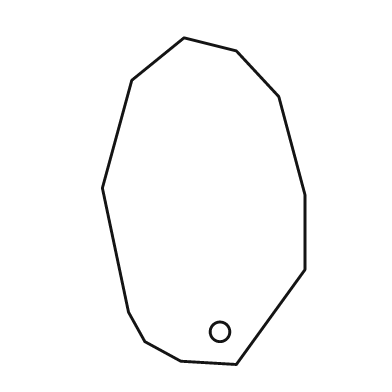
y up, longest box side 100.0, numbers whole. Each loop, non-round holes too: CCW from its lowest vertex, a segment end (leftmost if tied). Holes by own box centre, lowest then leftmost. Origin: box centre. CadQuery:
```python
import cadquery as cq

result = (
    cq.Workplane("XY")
    .moveTo(10.0, -50.0)
    .lineTo(31.0, -21.0)
    .lineTo(31.0, 2.0)
    .lineTo(23.0, 32.0)
    .lineTo(10.0, 46.0)
    .lineTo(-6.0, 50.0)
    .lineTo(-22.0, 37.0)
    .lineTo(-31.0, 4.0)
    .lineTo(-23.0, -34.0)
    .lineTo(-18.0, -43.0)
    .lineTo(-7.0, -49.0)
    .close()
    .moveTo(5.0, -40.0)
    .circle(3.0)
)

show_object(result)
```